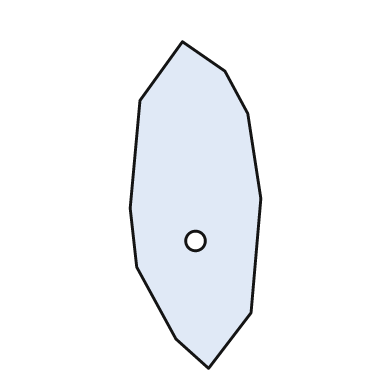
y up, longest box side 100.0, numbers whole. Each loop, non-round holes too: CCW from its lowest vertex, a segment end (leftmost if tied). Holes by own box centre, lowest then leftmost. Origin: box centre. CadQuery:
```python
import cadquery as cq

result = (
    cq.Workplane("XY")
    .moveTo(4.0, -50.0)
    .lineTo(17.0, -33.0)
    .lineTo(20.0, 2.0)
    .lineTo(16.0, 28.0)
    .lineTo(9.0, 41.0)
    .lineTo(-4.0, 50.0)
    .lineTo(-17.0, 32.0)
    .lineTo(-20.0, -1.0)
    .lineTo(-18.0, -19.0)
    .lineTo(-6.0, -41.0)
    .close()
    .moveTo(0.0, -11.0)
    .circle(3.0)
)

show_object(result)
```